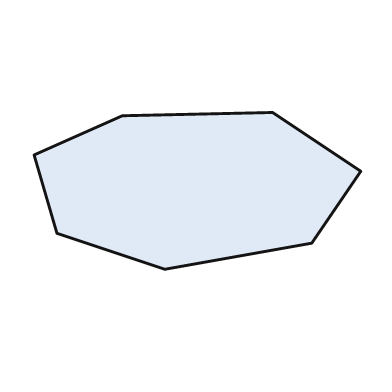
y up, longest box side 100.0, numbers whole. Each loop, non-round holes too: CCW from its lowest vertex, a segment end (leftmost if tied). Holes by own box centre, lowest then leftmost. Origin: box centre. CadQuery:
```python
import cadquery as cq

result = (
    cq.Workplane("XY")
    .moveTo(-10.0, -24.0)
    .lineTo(35.0, -16.0)
    .lineTo(50.0, 6.0)
    .lineTo(23.0, 24.0)
    .lineTo(-23.0, 23.0)
    .lineTo(-50.0, 11.0)
    .lineTo(-43.0, -13.0)
    .close()
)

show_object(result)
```